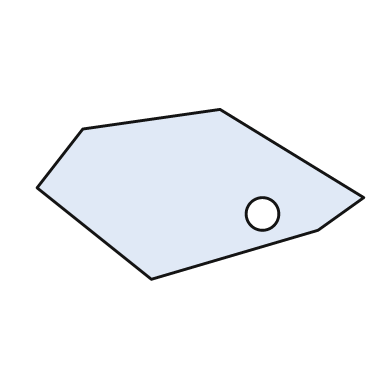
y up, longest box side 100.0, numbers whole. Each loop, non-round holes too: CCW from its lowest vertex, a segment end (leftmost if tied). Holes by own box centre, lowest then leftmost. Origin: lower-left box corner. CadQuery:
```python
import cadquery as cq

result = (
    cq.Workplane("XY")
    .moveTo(35.0, 0.0)
    .lineTo(86.0, 15.0)
    .lineTo(100.0, 25.0)
    .lineTo(56.0, 52.0)
    .lineTo(14.0, 46.0)
    .lineTo(0.0, 28.0)
    .close()
    .moveTo(69.0, 20.0)
    .circle(5.0)
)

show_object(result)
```